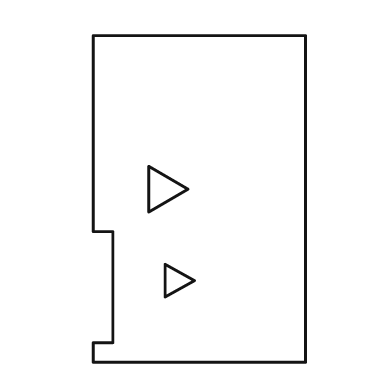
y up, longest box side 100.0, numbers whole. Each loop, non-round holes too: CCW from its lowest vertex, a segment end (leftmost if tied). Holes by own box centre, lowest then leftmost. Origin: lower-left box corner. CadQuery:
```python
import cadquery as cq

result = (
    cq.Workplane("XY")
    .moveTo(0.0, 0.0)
    .lineTo(65.0, 0.0)
    .lineTo(65.0, 100.0)
    .lineTo(0.0, 100.0)
    .lineTo(0.0, 40.0)
    .lineTo(6.0, 40.0)
    .lineTo(6.0, 6.0)
    .lineTo(0.0, 6.0)
    .close()
    .moveTo(22.0, 20.0)
    .lineTo(31.0, 25.0)
    .lineTo(22.0, 30.0)
    .close()
    .moveTo(17.0, 46.0)
    .lineTo(29.0, 53.0)
    .lineTo(17.0, 60.0)
    .close()
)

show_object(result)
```